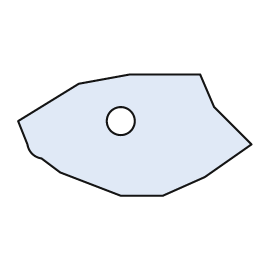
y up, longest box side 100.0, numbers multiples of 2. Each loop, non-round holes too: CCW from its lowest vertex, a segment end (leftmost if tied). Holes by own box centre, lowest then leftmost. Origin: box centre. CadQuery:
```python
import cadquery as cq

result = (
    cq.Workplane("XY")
    .moveTo(-6.0, -26.0)
    .lineTo(12.0, -26.0)
    .lineTo(30.0, -18.0)
    .lineTo(50.0, -4.0)
    .lineTo(34.0, 12.0)
    .lineTo(28.0, 26.0)
    .lineTo(-2.0, 26.0)
    .lineTo(-24.0, 22.0)
    .lineTo(-50.0, 6.0)
    .lineTo(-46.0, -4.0)
    .threePointArc((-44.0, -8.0), (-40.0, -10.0))
    .lineTo(-32.0, -16.0)
    .close()
    .moveTo(-6.0, 6.0)
    .circle(6.0)
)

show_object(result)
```